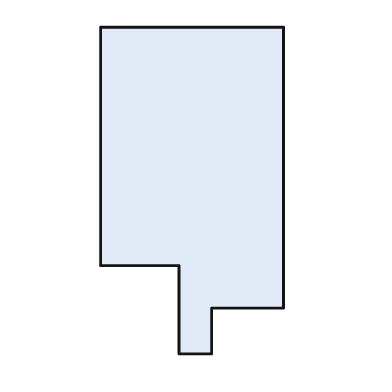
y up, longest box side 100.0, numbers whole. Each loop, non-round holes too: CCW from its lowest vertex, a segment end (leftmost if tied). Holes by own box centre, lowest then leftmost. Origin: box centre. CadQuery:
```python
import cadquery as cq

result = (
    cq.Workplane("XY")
    .moveTo(-4.0, -50.0)
    .lineTo(6.0, -50.0)
    .lineTo(6.0, -36.0)
    .lineTo(28.0, -36.0)
    .lineTo(28.0, 50.0)
    .lineTo(-28.0, 50.0)
    .lineTo(-28.0, -23.0)
    .lineTo(-4.0, -23.0)
    .close()
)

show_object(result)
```